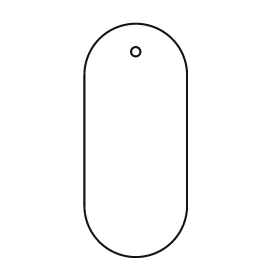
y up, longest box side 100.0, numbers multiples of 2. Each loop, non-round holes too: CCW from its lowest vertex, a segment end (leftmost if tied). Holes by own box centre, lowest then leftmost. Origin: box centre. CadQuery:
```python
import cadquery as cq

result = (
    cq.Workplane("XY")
    .moveTo(-22.0, -28.0)
    .threePointArc((0.0, -50.0), (22.0, -28.0))
    .lineTo(22.0, 28.0)
    .threePointArc((0.0, 50.0), (-22.0, 28.0))
    .close()
    .moveTo(0.0, 38.0)
    .circle(2.0)
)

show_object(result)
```